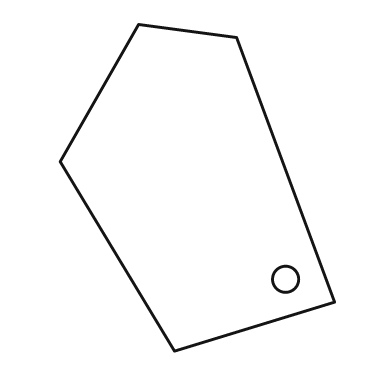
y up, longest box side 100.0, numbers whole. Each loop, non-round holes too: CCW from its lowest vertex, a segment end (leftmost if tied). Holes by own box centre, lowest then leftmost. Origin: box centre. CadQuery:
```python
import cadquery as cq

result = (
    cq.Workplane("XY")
    .moveTo(-7.0, -50.0)
    .lineTo(42.0, -35.0)
    .lineTo(12.0, 46.0)
    .lineTo(-18.0, 50.0)
    .lineTo(-42.0, 8.0)
    .close()
    .moveTo(27.0, -28.0)
    .circle(4.0)
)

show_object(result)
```